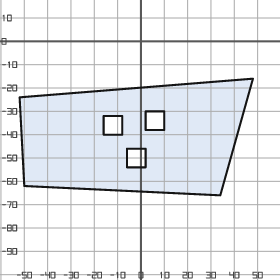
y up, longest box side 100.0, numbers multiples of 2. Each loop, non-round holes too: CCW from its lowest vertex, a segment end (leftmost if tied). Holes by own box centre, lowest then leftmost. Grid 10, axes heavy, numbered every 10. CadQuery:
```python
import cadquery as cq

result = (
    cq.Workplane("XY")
    .moveTo(34.0, -66.0)
    .lineTo(48.0, -16.0)
    .lineTo(-52.0, -24.0)
    .lineTo(-50.0, -62.0)
    .close()
    .moveTo(-6.0, -54.0)
    .lineTo(2.0, -54.0)
    .lineTo(2.0, -46.0)
    .lineTo(-6.0, -46.0)
    .close()
    .moveTo(-16.0, -40.0)
    .lineTo(-8.0, -40.0)
    .lineTo(-8.0, -32.0)
    .lineTo(-16.0, -32.0)
    .close()
    .moveTo(2.0, -38.0)
    .lineTo(10.0, -38.0)
    .lineTo(10.0, -30.0)
    .lineTo(2.0, -30.0)
    .close()
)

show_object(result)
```